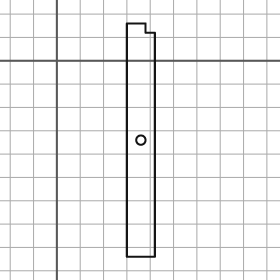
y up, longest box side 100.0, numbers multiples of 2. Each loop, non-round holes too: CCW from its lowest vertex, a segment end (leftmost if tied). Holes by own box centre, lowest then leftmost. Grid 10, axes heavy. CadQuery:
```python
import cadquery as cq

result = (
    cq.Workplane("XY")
    .moveTo(30.0, -84.0)
    .lineTo(42.0, -84.0)
    .lineTo(42.0, 12.0)
    .lineTo(38.0, 12.0)
    .lineTo(38.0, 16.0)
    .lineTo(30.0, 16.0)
    .close()
    .moveTo(36.0, -34.0)
    .circle(2.0)
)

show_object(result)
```